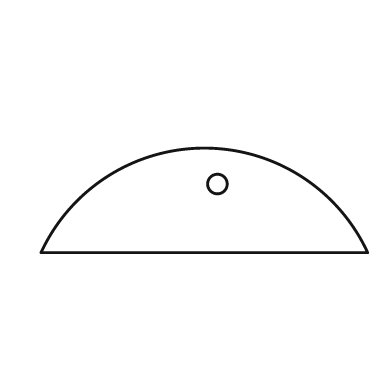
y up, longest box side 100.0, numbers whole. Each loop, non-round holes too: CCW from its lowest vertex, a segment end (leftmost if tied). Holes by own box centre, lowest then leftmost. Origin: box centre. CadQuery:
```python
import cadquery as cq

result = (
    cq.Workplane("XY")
    .moveTo(-50.0, -16.0)
    .lineTo(50.0, -16.0)
    .threePointArc((0.0, 16.0), (-50.0, -16.0))
    .close()
    .moveTo(4.0, 5.0)
    .circle(3.0)
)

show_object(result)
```